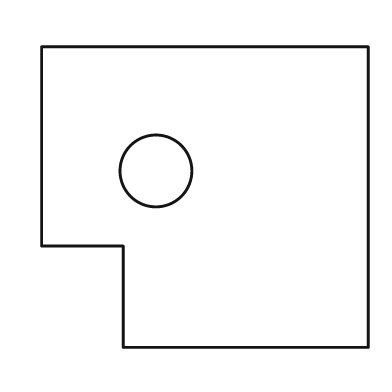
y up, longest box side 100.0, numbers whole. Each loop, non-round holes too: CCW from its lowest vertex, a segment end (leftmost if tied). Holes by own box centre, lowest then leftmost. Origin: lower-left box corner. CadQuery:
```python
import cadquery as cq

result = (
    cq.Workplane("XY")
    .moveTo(25.0, 0.0)
    .lineTo(100.0, 0.0)
    .lineTo(100.0, 92.0)
    .lineTo(0.0, 92.0)
    .lineTo(0.0, 31.0)
    .lineTo(25.0, 31.0)
    .close()
    .moveTo(35.0, 54.0)
    .circle(11.0)
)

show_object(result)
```